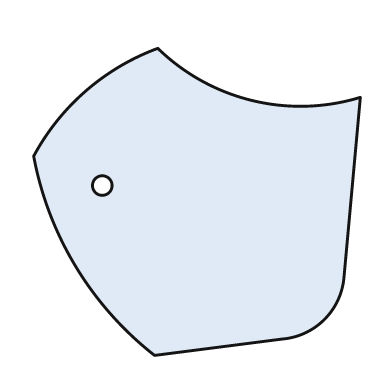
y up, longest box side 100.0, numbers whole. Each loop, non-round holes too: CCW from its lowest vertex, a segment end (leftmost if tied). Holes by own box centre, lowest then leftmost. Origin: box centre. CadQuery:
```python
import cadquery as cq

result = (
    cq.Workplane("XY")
    .moveTo(-13.0, -47.0)
    .lineTo(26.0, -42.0)
    .threePointArc((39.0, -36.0), (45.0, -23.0))
    .lineTo(50.0, 32.0)
    .threePointArc((17.0, 31.0), (-12.0, 47.0))
    .threePointArc((-34.0, 34.0), (-50.0, 14.0))
    .threePointArc((-37.0, -20.0), (-13.0, -47.0))
    .close()
    .moveTo(-29.0, 5.0)
    .circle(3.0)
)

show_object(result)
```